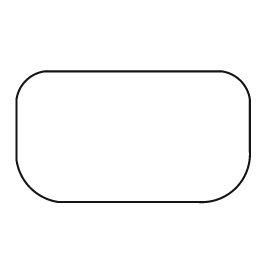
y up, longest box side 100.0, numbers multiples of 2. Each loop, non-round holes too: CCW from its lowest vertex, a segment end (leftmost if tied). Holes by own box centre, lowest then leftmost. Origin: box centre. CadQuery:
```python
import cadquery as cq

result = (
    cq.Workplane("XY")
    .moveTo(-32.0, -28.0)
    .lineTo(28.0, -28.0)
    .threePointArc((44.0, -22.0), (50.0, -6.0))
    .lineTo(50.0, 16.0)
    .threePointArc((46.0, 24.0), (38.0, 28.0))
    .lineTo(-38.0, 28.0)
    .threePointArc((-46.0, 24.0), (-50.0, 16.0))
    .lineTo(-50.0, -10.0)
    .threePointArc((-44.0, -22.0), (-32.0, -28.0))
    .close()
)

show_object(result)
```